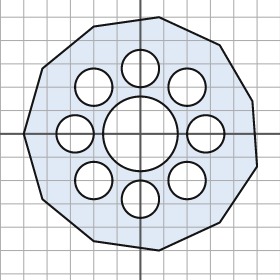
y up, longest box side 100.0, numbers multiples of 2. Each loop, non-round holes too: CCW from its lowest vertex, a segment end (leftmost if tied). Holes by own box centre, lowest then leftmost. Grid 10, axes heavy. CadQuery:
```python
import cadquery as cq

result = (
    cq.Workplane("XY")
    .moveTo(8.0, -50.0)
    .lineTo(34.0, -38.0)
    .lineTo(50.0, -14.0)
    .lineTo(48.0, 14.0)
    .lineTo(34.0, 38.0)
    .lineTo(8.0, 50.0)
    .lineTo(-20.0, 46.0)
    .lineTo(-42.0, 28.0)
    .lineTo(-50.0, 0.0)
    .lineTo(-42.0, -28.0)
    .lineTo(-20.0, -46.0)
    .close()
    .moveTo(0.0, -28.0)
    .circle(8.0)
    .moveTo(-20.0, -20.0)
    .circle(8.0)
    .moveTo(20.0, -20.0)
    .circle(8.0)
    .moveTo(-28.0, 0.0)
    .circle(8.0)
    .moveTo(0.0, 0.0)
    .circle(16.0)
    .moveTo(28.0, 0.0)
    .circle(8.0)
    .moveTo(-20.0, 20.0)
    .circle(8.0)
    .moveTo(20.0, 20.0)
    .circle(8.0)
    .moveTo(0.0, 28.0)
    .circle(8.0)
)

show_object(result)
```